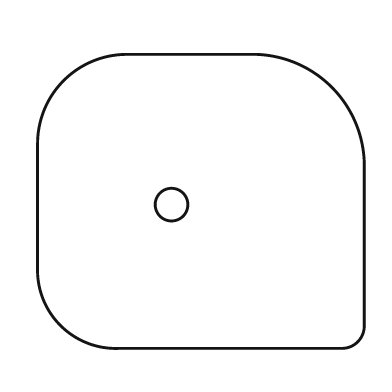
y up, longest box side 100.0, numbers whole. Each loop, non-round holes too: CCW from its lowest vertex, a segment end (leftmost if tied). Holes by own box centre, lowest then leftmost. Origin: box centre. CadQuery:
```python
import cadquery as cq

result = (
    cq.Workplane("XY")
    .moveTo(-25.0, -45.0)
    .lineTo(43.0, -45.0)
    .threePointArc((48.0, -43.0), (50.0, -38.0))
    .lineTo(50.0, 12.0)
    .threePointArc((40.0, 35.0), (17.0, 45.0))
    .lineTo(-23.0, 45.0)
    .threePointArc((-42.0, 37.0), (-50.0, 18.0))
    .lineTo(-50.0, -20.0)
    .threePointArc((-43.0, -38.0), (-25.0, -45.0))
    .close()
    .moveTo(-9.0, -1.0)
    .circle(5.0)
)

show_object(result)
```